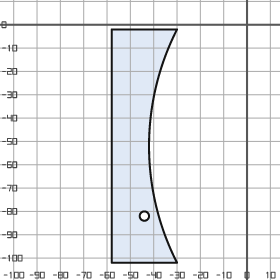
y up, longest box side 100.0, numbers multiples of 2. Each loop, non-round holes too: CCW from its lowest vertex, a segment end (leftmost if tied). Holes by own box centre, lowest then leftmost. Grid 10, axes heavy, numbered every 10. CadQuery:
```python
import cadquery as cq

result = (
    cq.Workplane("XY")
    .moveTo(-58.0, -102.0)
    .lineTo(-30.0, -102.0)
    .threePointArc((-42.0, -52.0), (-30.0, -2.0))
    .lineTo(-58.0, -2.0)
    .close()
    .moveTo(-44.0, -82.0)
    .circle(2.0)
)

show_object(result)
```